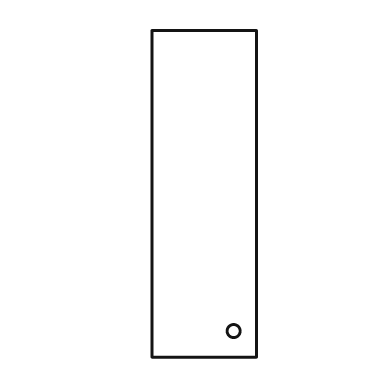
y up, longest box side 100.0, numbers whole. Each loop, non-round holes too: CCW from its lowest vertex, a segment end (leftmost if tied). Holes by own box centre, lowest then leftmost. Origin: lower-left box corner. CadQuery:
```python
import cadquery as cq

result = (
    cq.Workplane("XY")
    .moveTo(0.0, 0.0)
    .lineTo(32.0, 0.0)
    .lineTo(32.0, 100.0)
    .lineTo(0.0, 100.0)
    .close()
    .moveTo(25.0, 8.0)
    .circle(2.0)
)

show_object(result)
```